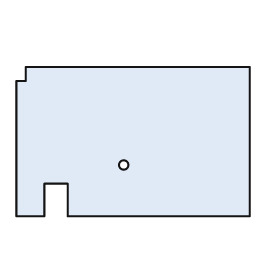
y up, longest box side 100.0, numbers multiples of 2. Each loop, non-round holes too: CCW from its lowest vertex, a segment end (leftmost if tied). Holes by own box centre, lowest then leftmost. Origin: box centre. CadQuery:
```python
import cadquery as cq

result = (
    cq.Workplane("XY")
    .moveTo(-50.0, -32.0)
    .lineTo(-38.0, -32.0)
    .lineTo(-38.0, -18.0)
    .lineTo(-28.0, -18.0)
    .lineTo(-28.0, -32.0)
    .lineTo(50.0, -32.0)
    .lineTo(50.0, 32.0)
    .lineTo(-46.0, 32.0)
    .lineTo(-46.0, 26.0)
    .lineTo(-50.0, 26.0)
    .close()
    .moveTo(-4.0, -10.0)
    .circle(2.0)
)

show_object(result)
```